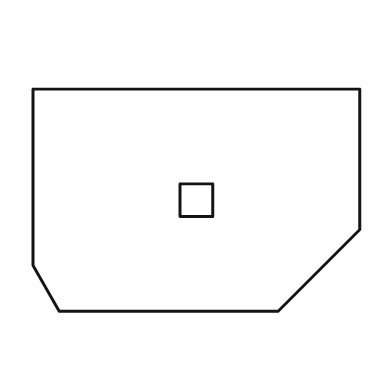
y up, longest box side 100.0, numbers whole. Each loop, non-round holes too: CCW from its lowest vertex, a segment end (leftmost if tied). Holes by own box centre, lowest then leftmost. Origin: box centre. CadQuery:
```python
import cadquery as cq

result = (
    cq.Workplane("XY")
    .moveTo(-42.0, -34.0)
    .lineTo(25.0, -34.0)
    .lineTo(50.0, -9.0)
    .lineTo(50.0, 34.0)
    .lineTo(-50.0, 34.0)
    .lineTo(-50.0, -20.0)
    .close()
    .moveTo(-5.0, -5.0)
    .lineTo(5.0, -5.0)
    .lineTo(5.0, 5.0)
    .lineTo(-5.0, 5.0)
    .close()
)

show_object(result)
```